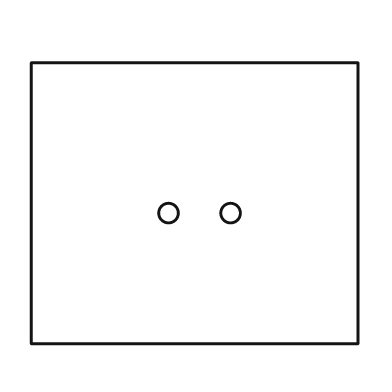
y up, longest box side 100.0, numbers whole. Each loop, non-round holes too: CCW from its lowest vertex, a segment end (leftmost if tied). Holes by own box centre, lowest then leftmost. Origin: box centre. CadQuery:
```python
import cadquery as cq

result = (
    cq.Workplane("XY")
    .moveTo(-50.0, -43.0)
    .lineTo(50.0, -43.0)
    .lineTo(50.0, 43.0)
    .lineTo(-50.0, 43.0)
    .close()
    .moveTo(-8.0, -3.0)
    .circle(3.0)
    .moveTo(11.0, -3.0)
    .circle(3.0)
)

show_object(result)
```